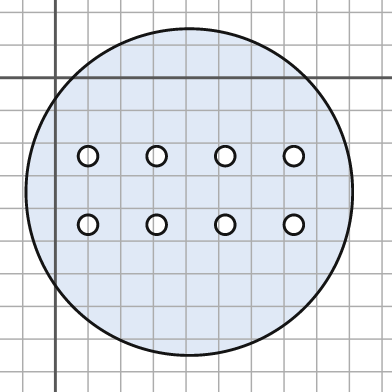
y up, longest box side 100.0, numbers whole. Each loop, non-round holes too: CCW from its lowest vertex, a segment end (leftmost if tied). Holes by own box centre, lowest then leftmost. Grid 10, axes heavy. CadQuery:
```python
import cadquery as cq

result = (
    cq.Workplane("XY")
    .moveTo(41.0, -35.0)
    .circle(50.0)
    .moveTo(10.0, -45.0)
    .circle(3.0)
    .moveTo(31.0, -45.0)
    .circle(3.0)
    .moveTo(52.0, -45.0)
    .circle(3.0)
    .moveTo(73.0, -45.0)
    .circle(3.0)
    .moveTo(10.0, -24.0)
    .circle(3.0)
    .moveTo(31.0, -24.0)
    .circle(3.0)
    .moveTo(52.0, -24.0)
    .circle(3.0)
    .moveTo(73.0, -24.0)
    .circle(3.0)
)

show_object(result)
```